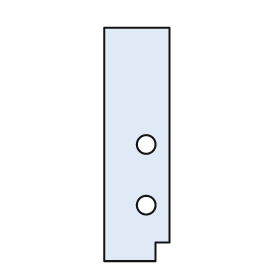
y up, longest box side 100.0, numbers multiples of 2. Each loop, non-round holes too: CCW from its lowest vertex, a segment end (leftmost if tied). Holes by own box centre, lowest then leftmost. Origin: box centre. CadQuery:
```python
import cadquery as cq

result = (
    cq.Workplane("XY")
    .moveTo(-14.0, -50.0)
    .lineTo(8.0, -50.0)
    .lineTo(8.0, -42.0)
    .lineTo(14.0, -42.0)
    .lineTo(14.0, 50.0)
    .lineTo(-14.0, 50.0)
    .close()
    .moveTo(4.0, -26.0)
    .circle(4.0)
    .moveTo(4.0, 0.0)
    .circle(4.0)
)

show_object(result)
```